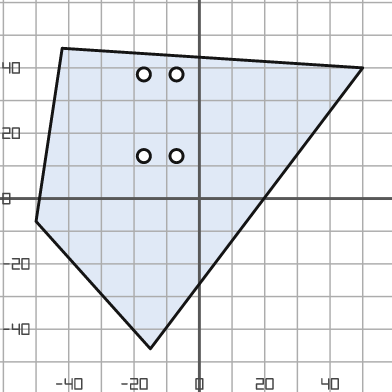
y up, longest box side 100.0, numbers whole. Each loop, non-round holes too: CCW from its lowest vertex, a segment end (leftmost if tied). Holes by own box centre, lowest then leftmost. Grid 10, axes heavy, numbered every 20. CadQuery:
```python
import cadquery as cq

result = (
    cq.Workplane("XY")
    .moveTo(-15.0, -46.0)
    .lineTo(50.0, 40.0)
    .lineTo(-42.0, 46.0)
    .lineTo(-50.0, -7.0)
    .close()
    .moveTo(-17.0, 13.0)
    .circle(2.0)
    .moveTo(-7.0, 13.0)
    .circle(2.0)
    .moveTo(-17.0, 38.0)
    .circle(2.0)
    .moveTo(-7.0, 38.0)
    .circle(2.0)
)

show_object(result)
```